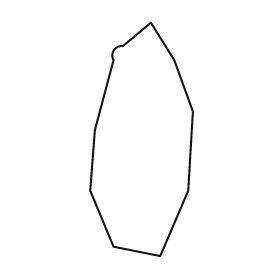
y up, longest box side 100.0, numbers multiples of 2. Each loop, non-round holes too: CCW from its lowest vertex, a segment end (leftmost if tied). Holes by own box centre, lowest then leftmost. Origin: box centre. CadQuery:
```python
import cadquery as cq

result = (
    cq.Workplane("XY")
    .moveTo(8.0, -50.0)
    .lineTo(20.0, -22.0)
    .lineTo(22.0, 12.0)
    .lineTo(14.0, 34.0)
    .lineTo(4.0, 50.0)
    .lineTo(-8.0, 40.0)
    .threePointArc((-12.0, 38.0), (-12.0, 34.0))
    .lineTo(-20.0, 4.0)
    .lineTo(-22.0, -22.0)
    .lineTo(-12.0, -46.0)
    .close()
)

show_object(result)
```